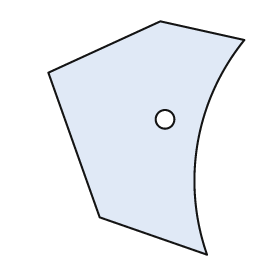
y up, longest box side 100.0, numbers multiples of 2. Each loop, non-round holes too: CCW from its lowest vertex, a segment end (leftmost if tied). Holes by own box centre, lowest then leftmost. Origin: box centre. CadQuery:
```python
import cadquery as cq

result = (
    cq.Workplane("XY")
    .moveTo(26.0, -50.0)
    .threePointArc((22.0, -2.0), (42.0, 42.0))
    .lineTo(6.0, 50.0)
    .lineTo(-42.0, 28.0)
    .lineTo(-20.0, -34.0)
    .close()
    .moveTo(8.0, 8.0)
    .circle(4.0)
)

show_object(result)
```